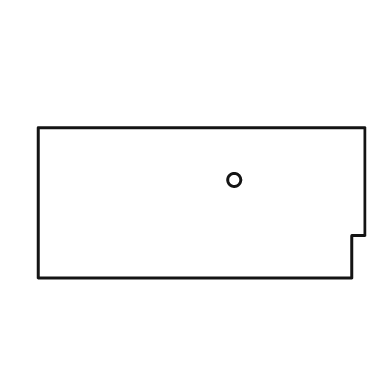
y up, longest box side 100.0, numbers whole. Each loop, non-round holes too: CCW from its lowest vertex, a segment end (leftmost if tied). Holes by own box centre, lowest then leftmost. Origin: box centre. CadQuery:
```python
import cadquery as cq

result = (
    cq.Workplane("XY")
    .moveTo(-50.0, -23.0)
    .lineTo(46.0, -23.0)
    .lineTo(46.0, -10.0)
    .lineTo(50.0, -10.0)
    .lineTo(50.0, 23.0)
    .lineTo(-50.0, 23.0)
    .close()
    .moveTo(10.0, 7.0)
    .circle(2.0)
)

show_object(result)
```